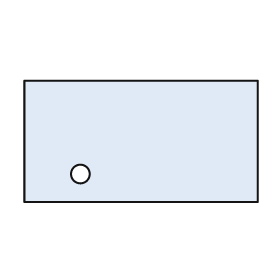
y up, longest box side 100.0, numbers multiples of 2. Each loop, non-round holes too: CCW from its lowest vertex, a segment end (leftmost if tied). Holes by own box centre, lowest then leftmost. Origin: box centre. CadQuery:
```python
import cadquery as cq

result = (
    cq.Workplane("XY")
    .moveTo(-50.0, -26.0)
    .lineTo(50.0, -26.0)
    .lineTo(50.0, 26.0)
    .lineTo(-50.0, 26.0)
    .close()
    .moveTo(-26.0, -14.0)
    .circle(4.0)
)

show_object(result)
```